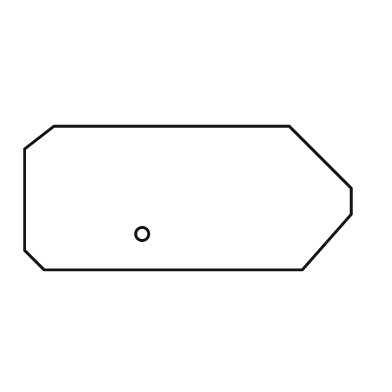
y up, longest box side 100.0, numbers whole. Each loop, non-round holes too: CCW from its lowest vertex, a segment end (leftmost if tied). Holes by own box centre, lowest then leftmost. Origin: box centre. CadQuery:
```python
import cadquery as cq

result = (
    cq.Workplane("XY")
    .moveTo(-44.0, -22.0)
    .lineTo(35.0, -22.0)
    .lineTo(50.0, -5.0)
    .lineTo(50.0, 3.0)
    .lineTo(31.0, 22.0)
    .lineTo(-41.0, 22.0)
    .lineTo(-50.0, 15.0)
    .lineTo(-50.0, -16.0)
    .close()
    .moveTo(-14.0, -11.0)
    .circle(2.0)
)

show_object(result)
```